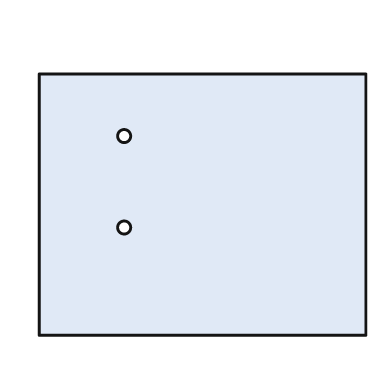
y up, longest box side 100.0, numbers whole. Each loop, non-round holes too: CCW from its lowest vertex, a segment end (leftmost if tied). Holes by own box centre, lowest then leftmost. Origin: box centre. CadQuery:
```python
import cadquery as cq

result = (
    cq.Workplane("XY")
    .moveTo(-50.0, -40.0)
    .lineTo(50.0, -40.0)
    .lineTo(50.0, 40.0)
    .lineTo(-50.0, 40.0)
    .close()
    .moveTo(-24.0, -7.0)
    .circle(2.0)
    .moveTo(-24.0, 21.0)
    .circle(2.0)
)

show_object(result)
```